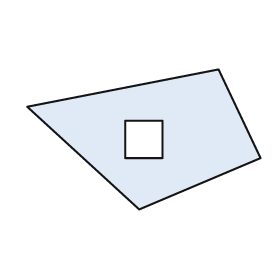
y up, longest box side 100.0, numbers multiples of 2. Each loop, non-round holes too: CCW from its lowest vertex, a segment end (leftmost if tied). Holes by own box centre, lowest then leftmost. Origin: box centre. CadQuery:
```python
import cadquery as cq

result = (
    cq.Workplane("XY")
    .moveTo(-2.0, -30.0)
    .lineTo(50.0, -8.0)
    .lineTo(32.0, 30.0)
    .lineTo(-50.0, 14.0)
    .close()
    .moveTo(-8.0, -8.0)
    .lineTo(8.0, -8.0)
    .lineTo(8.0, 8.0)
    .lineTo(-8.0, 8.0)
    .close()
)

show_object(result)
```